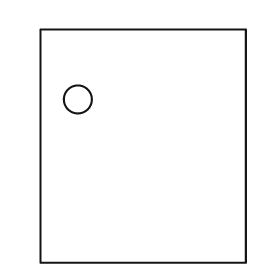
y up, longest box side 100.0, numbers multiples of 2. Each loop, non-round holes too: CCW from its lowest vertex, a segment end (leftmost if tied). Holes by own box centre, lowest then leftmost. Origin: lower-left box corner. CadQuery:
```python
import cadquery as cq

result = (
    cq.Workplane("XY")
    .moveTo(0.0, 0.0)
    .lineTo(88.0, 0.0)
    .lineTo(88.0, 100.0)
    .lineTo(0.0, 100.0)
    .close()
    .moveTo(16.0, 70.0)
    .circle(6.0)
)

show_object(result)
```